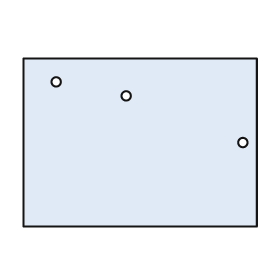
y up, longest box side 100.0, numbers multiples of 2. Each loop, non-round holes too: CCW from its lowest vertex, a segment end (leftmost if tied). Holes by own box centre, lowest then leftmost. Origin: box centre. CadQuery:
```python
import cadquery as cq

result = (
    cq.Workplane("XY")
    .moveTo(-50.0, -36.0)
    .lineTo(50.0, -36.0)
    .lineTo(50.0, 36.0)
    .lineTo(-50.0, 36.0)
    .close()
    .moveTo(44.0, 0.0)
    .circle(2.0)
    .moveTo(-6.0, 20.0)
    .circle(2.0)
    .moveTo(-36.0, 26.0)
    .circle(2.0)
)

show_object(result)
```